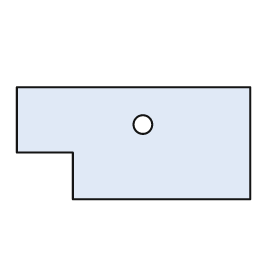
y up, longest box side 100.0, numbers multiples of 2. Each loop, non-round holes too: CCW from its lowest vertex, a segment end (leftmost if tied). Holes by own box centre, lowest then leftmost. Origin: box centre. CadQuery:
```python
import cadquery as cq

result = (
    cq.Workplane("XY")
    .moveTo(-26.0, -24.0)
    .lineTo(50.0, -24.0)
    .lineTo(50.0, 24.0)
    .lineTo(-50.0, 24.0)
    .lineTo(-50.0, -4.0)
    .lineTo(-26.0, -4.0)
    .close()
    .moveTo(4.0, 8.0)
    .circle(4.0)
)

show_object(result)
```